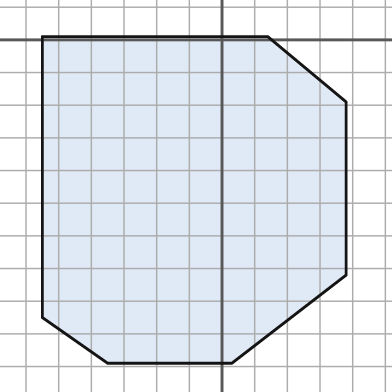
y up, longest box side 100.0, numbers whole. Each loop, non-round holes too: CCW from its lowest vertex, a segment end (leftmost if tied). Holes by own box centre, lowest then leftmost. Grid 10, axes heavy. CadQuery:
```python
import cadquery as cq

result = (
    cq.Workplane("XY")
    .moveTo(-35.0, -99.0)
    .lineTo(3.0, -99.0)
    .lineTo(38.0, -72.0)
    .lineTo(38.0, -19.0)
    .lineTo(14.0, 1.0)
    .lineTo(-55.0, 1.0)
    .lineTo(-55.0, -85.0)
    .close()
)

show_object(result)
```